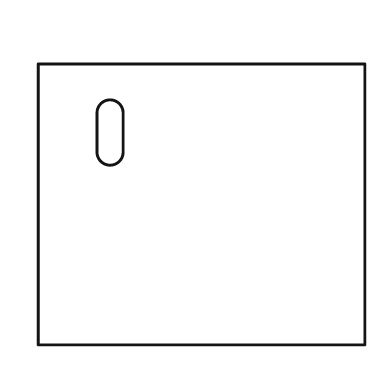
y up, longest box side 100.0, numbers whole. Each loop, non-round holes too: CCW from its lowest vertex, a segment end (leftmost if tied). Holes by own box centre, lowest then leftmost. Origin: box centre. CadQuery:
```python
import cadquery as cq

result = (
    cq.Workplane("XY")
    .moveTo(-50.0, -43.0)
    .lineTo(50.0, -43.0)
    .lineTo(50.0, 43.0)
    .lineTo(-50.0, 43.0)
    .close()
    .moveTo(-32.0, 16.0)
    .threePointArc((-28.0, 12.0), (-24.0, 16.0))
    .lineTo(-24.0, 28.0)
    .threePointArc((-28.0, 32.0), (-32.0, 28.0))
    .close()
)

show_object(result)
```